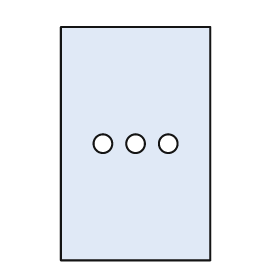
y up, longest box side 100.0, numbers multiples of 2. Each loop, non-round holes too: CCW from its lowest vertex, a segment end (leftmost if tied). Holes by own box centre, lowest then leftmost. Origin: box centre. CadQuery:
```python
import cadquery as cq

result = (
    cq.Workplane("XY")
    .moveTo(-32.0, -50.0)
    .lineTo(32.0, -50.0)
    .lineTo(32.0, 50.0)
    .lineTo(-32.0, 50.0)
    .close()
    .moveTo(-14.0, 0.0)
    .circle(4.0)
    .moveTo(0.0, 0.0)
    .circle(4.0)
    .moveTo(14.0, 0.0)
    .circle(4.0)
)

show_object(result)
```